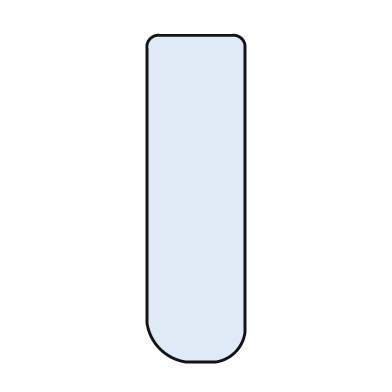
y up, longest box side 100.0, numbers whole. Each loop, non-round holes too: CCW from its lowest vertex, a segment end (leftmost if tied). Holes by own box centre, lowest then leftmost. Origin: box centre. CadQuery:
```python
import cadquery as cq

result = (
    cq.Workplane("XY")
    .moveTo(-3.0, -50.0)
    .lineTo(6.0, -50.0)
    .threePointArc((12.0, -47.0), (15.0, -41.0))
    .lineTo(15.0, 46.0)
    .threePointArc((14.0, 49.0), (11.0, 50.0))
    .lineTo(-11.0, 50.0)
    .threePointArc((-14.0, 49.0), (-15.0, 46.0))
    .lineTo(-15.0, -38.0)
    .threePointArc((-11.0, -46.0), (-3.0, -50.0))
    .close()
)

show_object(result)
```